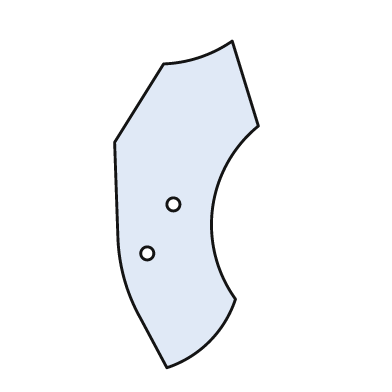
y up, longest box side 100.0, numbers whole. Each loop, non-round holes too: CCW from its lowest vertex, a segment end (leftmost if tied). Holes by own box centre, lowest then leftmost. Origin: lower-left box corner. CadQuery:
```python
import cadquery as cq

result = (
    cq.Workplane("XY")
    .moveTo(16.0, 0.0)
    .threePointArc((29.0, 8.0), (37.0, 21.0))
    .threePointArc((30.0, 49.0), (44.0, 74.0))
    .lineTo(36.0, 100.0)
    .threePointArc((26.0, 95.0), (15.0, 93.0))
    .lineTo(0.0, 69.0)
    .lineTo(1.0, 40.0)
    .threePointArc((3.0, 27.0), (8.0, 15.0))
    .close()
    .moveTo(10.0, 35.0)
    .circle(2.0)
    .moveTo(18.0, 50.0)
    .circle(2.0)
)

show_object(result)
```